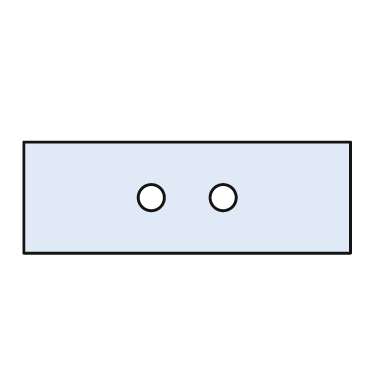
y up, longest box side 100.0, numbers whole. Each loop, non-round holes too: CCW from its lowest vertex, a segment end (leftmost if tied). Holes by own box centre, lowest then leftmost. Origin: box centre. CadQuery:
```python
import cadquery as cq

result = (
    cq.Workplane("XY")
    .moveTo(-50.0, -17.0)
    .lineTo(50.0, -17.0)
    .lineTo(50.0, 17.0)
    .lineTo(-50.0, 17.0)
    .close()
    .moveTo(-11.0, 0.0)
    .circle(4.0)
    .moveTo(11.0, 0.0)
    .circle(4.0)
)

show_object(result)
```